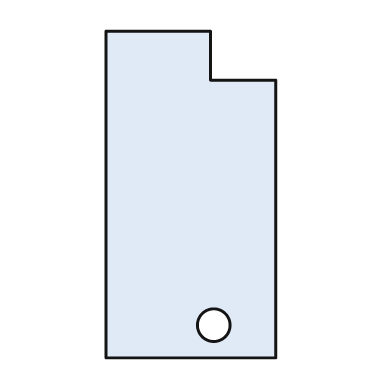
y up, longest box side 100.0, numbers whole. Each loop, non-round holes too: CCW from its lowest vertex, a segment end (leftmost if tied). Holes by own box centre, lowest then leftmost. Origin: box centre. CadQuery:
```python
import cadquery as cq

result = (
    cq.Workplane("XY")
    .moveTo(-26.0, -50.0)
    .lineTo(26.0, -50.0)
    .lineTo(26.0, 35.0)
    .lineTo(6.0, 35.0)
    .lineTo(6.0, 50.0)
    .lineTo(-26.0, 50.0)
    .close()
    .moveTo(7.0, -40.0)
    .circle(5.0)
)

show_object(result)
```